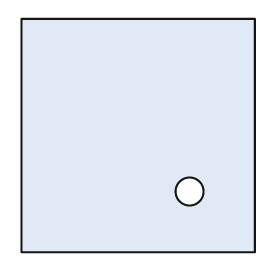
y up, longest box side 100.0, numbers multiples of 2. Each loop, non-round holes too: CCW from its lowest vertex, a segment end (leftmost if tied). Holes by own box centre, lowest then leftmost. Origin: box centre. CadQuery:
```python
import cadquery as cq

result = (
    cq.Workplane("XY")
    .moveTo(-50.0, -50.0)
    .lineTo(50.0, -50.0)
    .lineTo(50.0, 50.0)
    .lineTo(-50.0, 50.0)
    .close()
    .moveTo(22.0, -24.0)
    .circle(6.0)
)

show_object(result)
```